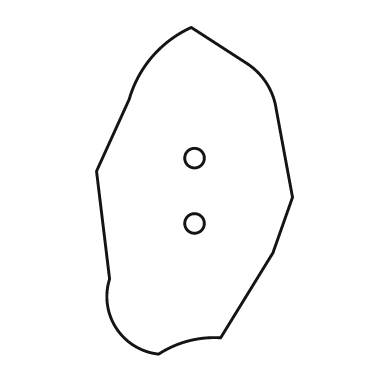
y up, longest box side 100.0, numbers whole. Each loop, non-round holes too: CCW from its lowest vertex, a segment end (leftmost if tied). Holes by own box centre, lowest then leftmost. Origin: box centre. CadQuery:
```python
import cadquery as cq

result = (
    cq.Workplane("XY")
    .moveTo(-11.0, -50.0)
    .threePointArc((-2.0, -46.0), (8.0, -45.0))
    .lineTo(24.0, -19.0)
    .lineTo(30.0, -2.0)
    .lineTo(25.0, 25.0)
    .threePointArc((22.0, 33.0), (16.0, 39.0))
    .lineTo(-1.0, 50.0)
    .threePointArc((-13.0, 41.0), (-20.0, 28.0))
    .lineTo(-30.0, 6.0)
    .lineTo(-26.0, -27.0)
    .threePointArc((-24.0, -42.0), (-11.0, -50.0))
    .close()
    .moveTo(0.0, -10.0)
    .circle(3.0)
    .moveTo(0.0, 10.0)
    .circle(3.0)
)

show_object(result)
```